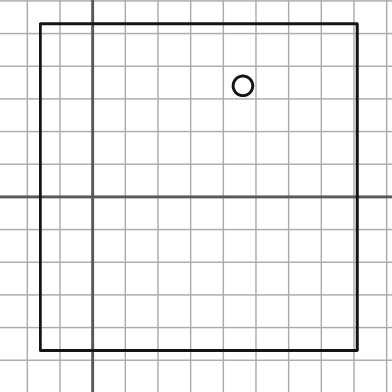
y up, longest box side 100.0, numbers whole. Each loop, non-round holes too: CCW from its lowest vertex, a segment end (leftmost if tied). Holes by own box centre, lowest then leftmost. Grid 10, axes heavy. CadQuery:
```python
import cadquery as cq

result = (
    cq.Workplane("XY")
    .moveTo(-16.0, -47.0)
    .lineTo(81.0, -47.0)
    .lineTo(81.0, 53.0)
    .lineTo(-16.0, 53.0)
    .close()
    .moveTo(46.0, 34.0)
    .circle(3.0)
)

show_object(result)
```